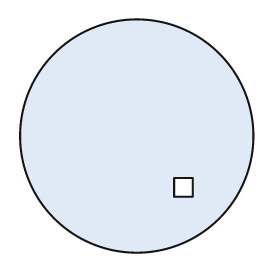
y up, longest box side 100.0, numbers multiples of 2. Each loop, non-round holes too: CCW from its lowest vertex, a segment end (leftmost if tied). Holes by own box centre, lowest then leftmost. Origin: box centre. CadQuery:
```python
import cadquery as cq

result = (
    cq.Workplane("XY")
    .moveTo(0.0, 0.0)
    .circle(50.0)
    .moveTo(16.0, -26.0)
    .lineTo(24.0, -26.0)
    .lineTo(24.0, -18.0)
    .lineTo(16.0, -18.0)
    .close()
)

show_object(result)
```